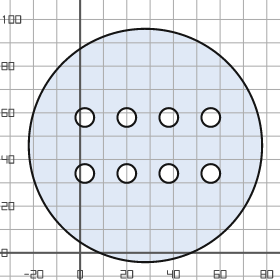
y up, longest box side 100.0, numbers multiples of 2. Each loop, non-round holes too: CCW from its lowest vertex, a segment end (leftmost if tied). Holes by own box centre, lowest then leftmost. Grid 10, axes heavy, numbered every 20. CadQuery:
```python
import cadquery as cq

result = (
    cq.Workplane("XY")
    .moveTo(28.0, 46.0)
    .circle(50.0)
    .moveTo(2.0, 34.0)
    .circle(4.0)
    .moveTo(20.0, 34.0)
    .circle(4.0)
    .moveTo(38.0, 34.0)
    .circle(4.0)
    .moveTo(56.0, 34.0)
    .circle(4.0)
    .moveTo(2.0, 58.0)
    .circle(4.0)
    .moveTo(20.0, 58.0)
    .circle(4.0)
    .moveTo(38.0, 58.0)
    .circle(4.0)
    .moveTo(56.0, 58.0)
    .circle(4.0)
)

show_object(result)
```